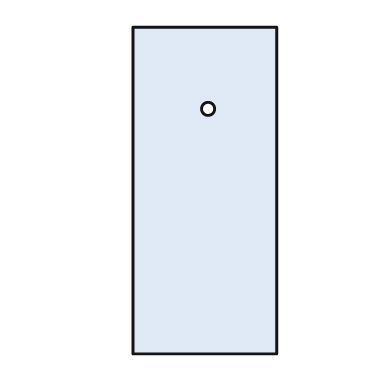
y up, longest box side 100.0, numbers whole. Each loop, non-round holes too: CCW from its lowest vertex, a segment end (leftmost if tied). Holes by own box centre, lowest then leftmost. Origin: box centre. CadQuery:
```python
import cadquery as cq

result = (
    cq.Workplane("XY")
    .moveTo(-22.0, -50.0)
    .lineTo(22.0, -50.0)
    .lineTo(22.0, 50.0)
    .lineTo(-22.0, 50.0)
    .close()
    .moveTo(1.0, 25.0)
    .circle(2.0)
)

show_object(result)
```